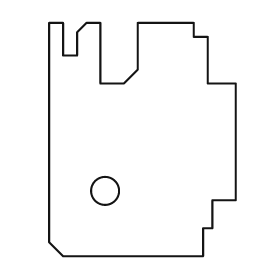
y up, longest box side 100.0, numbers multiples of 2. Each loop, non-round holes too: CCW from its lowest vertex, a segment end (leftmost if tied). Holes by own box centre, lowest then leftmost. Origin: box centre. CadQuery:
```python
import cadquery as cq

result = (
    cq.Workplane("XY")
    .moveTo(-34.0, -50.0)
    .lineTo(26.0, -50.0)
    .lineTo(26.0, -38.0)
    .lineTo(30.0, -38.0)
    .lineTo(30.0, -26.0)
    .lineTo(40.0, -26.0)
    .lineTo(40.0, 24.0)
    .lineTo(28.0, 24.0)
    .lineTo(28.0, 44.0)
    .lineTo(22.0, 44.0)
    .lineTo(22.0, 50.0)
    .lineTo(-2.0, 50.0)
    .lineTo(-2.0, 30.0)
    .lineTo(-8.0, 24.0)
    .lineTo(-18.0, 24.0)
    .lineTo(-18.0, 50.0)
    .lineTo(-24.0, 50.0)
    .lineTo(-28.0, 46.0)
    .lineTo(-28.0, 36.0)
    .lineTo(-34.0, 36.0)
    .lineTo(-34.0, 50.0)
    .lineTo(-40.0, 50.0)
    .lineTo(-40.0, -44.0)
    .close()
    .moveTo(-16.0, -22.0)
    .circle(6.0)
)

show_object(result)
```